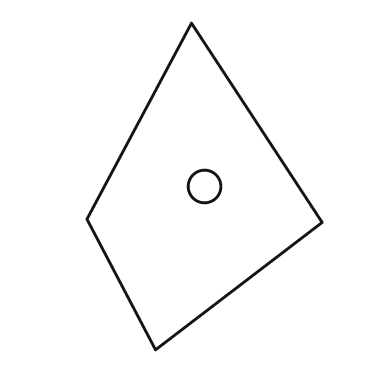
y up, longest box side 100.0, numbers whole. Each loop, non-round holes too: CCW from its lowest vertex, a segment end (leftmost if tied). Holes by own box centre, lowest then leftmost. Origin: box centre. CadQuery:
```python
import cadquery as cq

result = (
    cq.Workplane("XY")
    .moveTo(-15.0, -50.0)
    .lineTo(36.0, -11.0)
    .lineTo(-4.0, 50.0)
    .lineTo(-36.0, -10.0)
    .close()
    .moveTo(0.0, 0.0)
    .circle(5.0)
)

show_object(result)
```